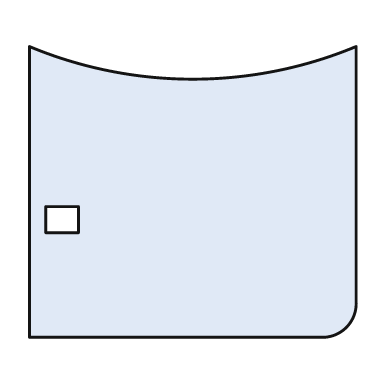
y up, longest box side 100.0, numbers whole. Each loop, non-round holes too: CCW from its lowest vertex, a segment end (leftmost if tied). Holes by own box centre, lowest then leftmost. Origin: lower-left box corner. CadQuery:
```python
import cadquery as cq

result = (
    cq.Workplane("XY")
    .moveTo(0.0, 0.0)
    .lineTo(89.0, 0.0)
    .threePointArc((97.0, 3.0), (100.0, 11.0))
    .lineTo(100.0, 89.0)
    .threePointArc((50.0, 79.0), (0.0, 89.0))
    .close()
    .moveTo(5.0, 32.0)
    .lineTo(15.0, 32.0)
    .lineTo(15.0, 40.0)
    .lineTo(5.0, 40.0)
    .close()
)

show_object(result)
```